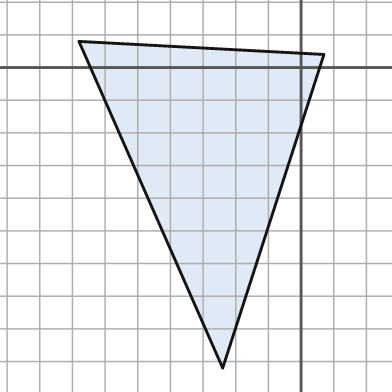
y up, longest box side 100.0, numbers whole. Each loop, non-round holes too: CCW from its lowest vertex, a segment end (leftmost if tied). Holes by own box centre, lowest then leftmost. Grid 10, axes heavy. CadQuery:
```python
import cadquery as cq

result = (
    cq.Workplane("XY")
    .moveTo(-24.0, -92.0)
    .lineTo(7.0, 4.0)
    .lineTo(-68.0, 8.0)
    .close()
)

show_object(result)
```